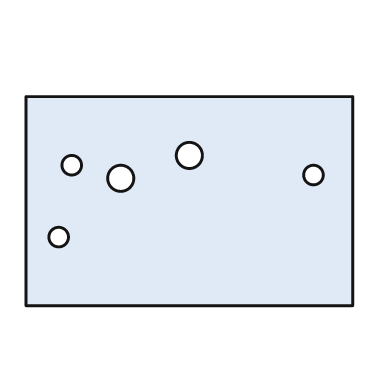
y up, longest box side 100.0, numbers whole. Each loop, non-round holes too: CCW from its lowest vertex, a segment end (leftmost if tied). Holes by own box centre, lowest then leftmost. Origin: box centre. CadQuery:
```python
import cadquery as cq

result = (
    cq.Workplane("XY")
    .moveTo(-50.0, -32.0)
    .lineTo(50.0, -32.0)
    .lineTo(50.0, 32.0)
    .lineTo(-50.0, 32.0)
    .close()
    .moveTo(-40.0, -11.0)
    .circle(3.0)
    .moveTo(-21.0, 7.0)
    .circle(4.0)
    .moveTo(38.0, 8.0)
    .circle(3.0)
    .moveTo(-36.0, 11.0)
    .circle(3.0)
    .moveTo(0.0, 14.0)
    .circle(4.0)
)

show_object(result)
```